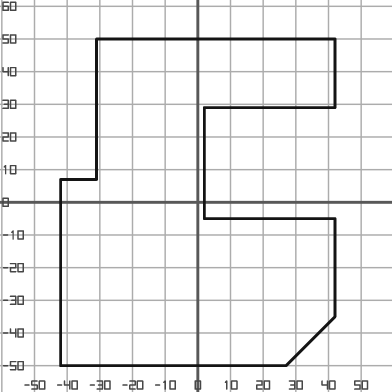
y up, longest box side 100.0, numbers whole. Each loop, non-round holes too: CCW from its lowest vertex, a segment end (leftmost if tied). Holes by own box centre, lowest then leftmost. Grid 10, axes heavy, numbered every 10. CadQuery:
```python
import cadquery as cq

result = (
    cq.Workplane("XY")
    .moveTo(-42.0, -50.0)
    .lineTo(27.0, -50.0)
    .lineTo(42.0, -35.0)
    .lineTo(42.0, -5.0)
    .lineTo(2.0, -5.0)
    .lineTo(2.0, 29.0)
    .lineTo(42.0, 29.0)
    .lineTo(42.0, 50.0)
    .lineTo(-31.0, 50.0)
    .lineTo(-31.0, 7.0)
    .lineTo(-42.0, 7.0)
    .close()
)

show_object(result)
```